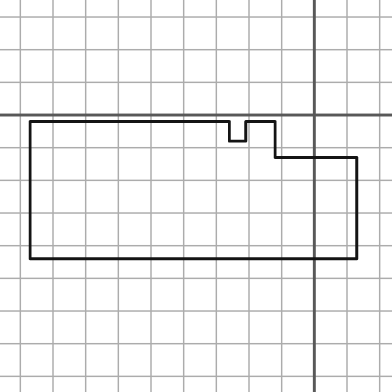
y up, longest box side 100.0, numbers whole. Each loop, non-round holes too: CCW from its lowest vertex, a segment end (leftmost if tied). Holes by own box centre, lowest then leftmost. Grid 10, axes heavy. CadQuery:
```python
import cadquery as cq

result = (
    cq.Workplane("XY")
    .moveTo(-87.0, -44.0)
    .lineTo(13.0, -44.0)
    .lineTo(13.0, -13.0)
    .lineTo(-12.0, -13.0)
    .lineTo(-12.0, -2.0)
    .lineTo(-21.0, -2.0)
    .lineTo(-21.0, -8.0)
    .lineTo(-26.0, -8.0)
    .lineTo(-26.0, -2.0)
    .lineTo(-87.0, -2.0)
    .close()
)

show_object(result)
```